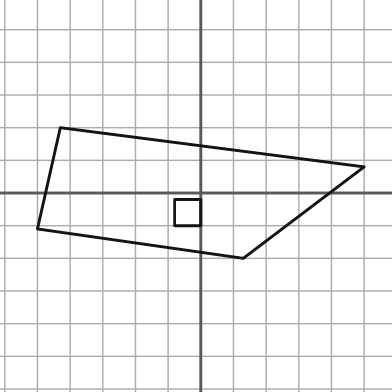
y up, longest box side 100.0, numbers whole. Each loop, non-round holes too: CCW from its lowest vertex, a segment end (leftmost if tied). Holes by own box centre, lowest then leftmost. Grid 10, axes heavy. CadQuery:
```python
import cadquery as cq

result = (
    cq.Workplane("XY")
    .moveTo(13.0, -20.0)
    .lineTo(50.0, 8.0)
    .lineTo(-43.0, 20.0)
    .lineTo(-50.0, -11.0)
    .close()
    .moveTo(-8.0, -10.0)
    .lineTo(0.0, -10.0)
    .lineTo(0.0, -2.0)
    .lineTo(-8.0, -2.0)
    .close()
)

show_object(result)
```